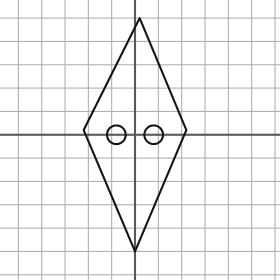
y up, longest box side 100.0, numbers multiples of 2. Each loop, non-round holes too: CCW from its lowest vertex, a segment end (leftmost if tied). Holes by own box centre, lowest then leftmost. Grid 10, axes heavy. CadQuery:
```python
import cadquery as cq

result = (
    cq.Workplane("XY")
    .moveTo(0.0, -50.0)
    .lineTo(22.0, 2.0)
    .lineTo(2.0, 50.0)
    .lineTo(-22.0, 2.0)
    .close()
    .moveTo(-8.0, 0.0)
    .circle(4.0)
    .moveTo(8.0, 0.0)
    .circle(4.0)
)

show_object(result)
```